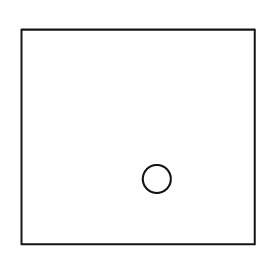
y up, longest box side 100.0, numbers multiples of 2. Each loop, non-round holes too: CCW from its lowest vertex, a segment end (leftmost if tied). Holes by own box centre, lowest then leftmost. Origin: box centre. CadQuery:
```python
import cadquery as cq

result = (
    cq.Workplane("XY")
    .moveTo(-50.0, -46.0)
    .lineTo(50.0, -46.0)
    .lineTo(50.0, 46.0)
    .lineTo(-50.0, 46.0)
    .close()
    .moveTo(8.0, -18.0)
    .circle(6.0)
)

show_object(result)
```